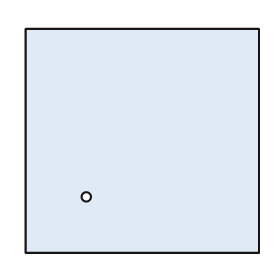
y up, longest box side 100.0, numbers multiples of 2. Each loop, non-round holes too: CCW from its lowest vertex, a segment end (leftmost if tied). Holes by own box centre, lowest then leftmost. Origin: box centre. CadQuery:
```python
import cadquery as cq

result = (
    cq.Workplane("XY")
    .moveTo(-50.0, -48.0)
    .lineTo(50.0, -48.0)
    .lineTo(50.0, 48.0)
    .lineTo(-50.0, 48.0)
    .close()
    .moveTo(-24.0, -24.0)
    .circle(2.0)
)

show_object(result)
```